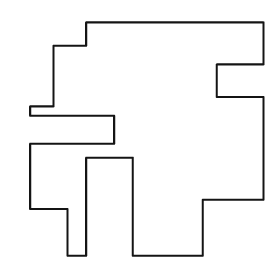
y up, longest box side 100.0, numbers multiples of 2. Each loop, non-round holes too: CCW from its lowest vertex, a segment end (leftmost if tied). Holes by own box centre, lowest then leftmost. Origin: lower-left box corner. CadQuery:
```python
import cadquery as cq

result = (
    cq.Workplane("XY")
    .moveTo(16.0, 0.0)
    .lineTo(24.0, 0.0)
    .lineTo(24.0, 42.0)
    .lineTo(44.0, 42.0)
    .lineTo(44.0, 0.0)
    .lineTo(74.0, 0.0)
    .lineTo(74.0, 24.0)
    .lineTo(100.0, 24.0)
    .lineTo(100.0, 68.0)
    .lineTo(80.0, 68.0)
    .lineTo(80.0, 82.0)
    .lineTo(100.0, 82.0)
    .lineTo(100.0, 100.0)
    .lineTo(24.0, 100.0)
    .lineTo(24.0, 90.0)
    .lineTo(10.0, 90.0)
    .lineTo(10.0, 64.0)
    .lineTo(0.0, 64.0)
    .lineTo(0.0, 60.0)
    .lineTo(36.0, 60.0)
    .lineTo(36.0, 48.0)
    .lineTo(0.0, 48.0)
    .lineTo(0.0, 20.0)
    .lineTo(16.0, 20.0)
    .close()
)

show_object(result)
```